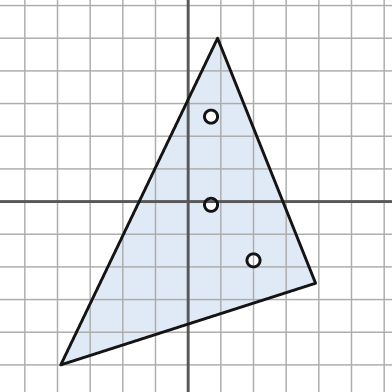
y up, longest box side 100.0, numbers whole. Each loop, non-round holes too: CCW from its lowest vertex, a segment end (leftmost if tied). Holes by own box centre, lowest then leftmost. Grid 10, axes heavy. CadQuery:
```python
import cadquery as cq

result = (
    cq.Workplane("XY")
    .moveTo(-39.0, -50.0)
    .lineTo(39.0, -25.0)
    .lineTo(9.0, 50.0)
    .close()
    .moveTo(20.0, -18.0)
    .circle(2.0)
    .moveTo(7.0, -1.0)
    .circle(2.0)
    .moveTo(7.0, 26.0)
    .circle(2.0)
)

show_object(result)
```